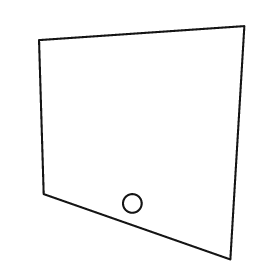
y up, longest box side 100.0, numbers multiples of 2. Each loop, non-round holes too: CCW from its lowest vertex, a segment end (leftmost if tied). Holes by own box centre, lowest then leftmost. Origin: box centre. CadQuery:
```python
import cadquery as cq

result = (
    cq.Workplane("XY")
    .moveTo(38.0, -50.0)
    .lineTo(44.0, 50.0)
    .lineTo(-44.0, 44.0)
    .lineTo(-42.0, -22.0)
    .close()
    .moveTo(-4.0, -26.0)
    .circle(4.0)
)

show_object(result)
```